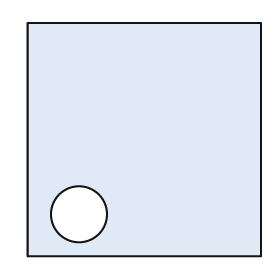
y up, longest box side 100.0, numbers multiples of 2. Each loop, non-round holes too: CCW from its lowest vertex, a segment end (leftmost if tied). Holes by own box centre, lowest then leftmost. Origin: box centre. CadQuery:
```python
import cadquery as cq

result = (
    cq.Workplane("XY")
    .moveTo(-50.0, -50.0)
    .lineTo(50.0, -50.0)
    .lineTo(50.0, 50.0)
    .lineTo(-50.0, 50.0)
    .close()
    .moveTo(-28.0, -32.0)
    .circle(12.0)
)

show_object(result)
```